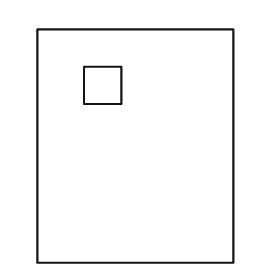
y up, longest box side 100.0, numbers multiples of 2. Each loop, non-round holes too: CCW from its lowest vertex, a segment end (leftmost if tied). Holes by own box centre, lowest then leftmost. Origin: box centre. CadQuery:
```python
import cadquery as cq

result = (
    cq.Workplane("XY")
    .moveTo(-42.0, -50.0)
    .lineTo(42.0, -50.0)
    .lineTo(42.0, 50.0)
    .lineTo(-42.0, 50.0)
    .close()
    .moveTo(-22.0, 18.0)
    .lineTo(-6.0, 18.0)
    .lineTo(-6.0, 34.0)
    .lineTo(-22.0, 34.0)
    .close()
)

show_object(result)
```